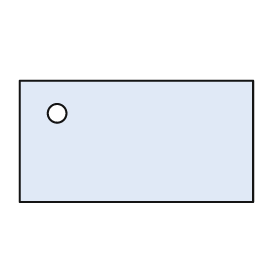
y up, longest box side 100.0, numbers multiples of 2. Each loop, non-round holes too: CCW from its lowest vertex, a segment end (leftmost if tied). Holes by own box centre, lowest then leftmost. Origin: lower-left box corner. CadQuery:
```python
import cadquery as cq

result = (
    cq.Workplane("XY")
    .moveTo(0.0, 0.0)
    .lineTo(100.0, 0.0)
    .lineTo(100.0, 52.0)
    .lineTo(0.0, 52.0)
    .close()
    .moveTo(16.0, 38.0)
    .circle(4.0)
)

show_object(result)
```